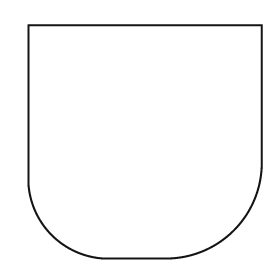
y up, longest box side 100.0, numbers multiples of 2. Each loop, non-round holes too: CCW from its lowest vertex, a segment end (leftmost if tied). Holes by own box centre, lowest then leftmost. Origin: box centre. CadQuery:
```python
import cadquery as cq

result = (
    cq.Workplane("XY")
    .moveTo(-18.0, -50.0)
    .lineTo(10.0, -50.0)
    .threePointArc((38.0, -38.0), (50.0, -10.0))
    .lineTo(50.0, 50.0)
    .lineTo(-50.0, 50.0)
    .lineTo(-50.0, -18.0)
    .threePointArc((-40.0, -40.0), (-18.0, -50.0))
    .close()
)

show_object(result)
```